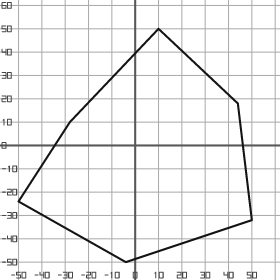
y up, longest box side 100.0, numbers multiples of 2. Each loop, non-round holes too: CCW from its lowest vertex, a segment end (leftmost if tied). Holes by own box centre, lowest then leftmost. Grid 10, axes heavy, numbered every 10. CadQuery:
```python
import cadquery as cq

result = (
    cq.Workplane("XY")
    .moveTo(-4.0, -50.0)
    .lineTo(50.0, -32.0)
    .lineTo(44.0, 18.0)
    .lineTo(10.0, 50.0)
    .lineTo(-28.0, 10.0)
    .lineTo(-50.0, -24.0)
    .close()
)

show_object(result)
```